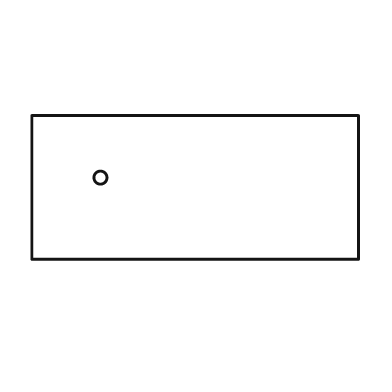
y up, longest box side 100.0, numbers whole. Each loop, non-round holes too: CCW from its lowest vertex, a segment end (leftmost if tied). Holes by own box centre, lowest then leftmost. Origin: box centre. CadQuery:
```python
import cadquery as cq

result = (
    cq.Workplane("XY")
    .moveTo(-50.0, -22.0)
    .lineTo(50.0, -22.0)
    .lineTo(50.0, 22.0)
    .lineTo(-50.0, 22.0)
    .close()
    .moveTo(-29.0, 3.0)
    .circle(2.0)
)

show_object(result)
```